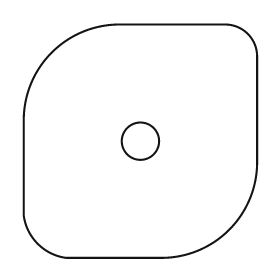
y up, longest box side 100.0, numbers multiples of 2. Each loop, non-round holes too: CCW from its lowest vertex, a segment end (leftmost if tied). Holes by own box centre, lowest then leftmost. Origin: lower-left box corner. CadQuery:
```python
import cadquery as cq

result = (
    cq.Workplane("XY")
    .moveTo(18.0, 0.0)
    .lineTo(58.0, 0.0)
    .threePointArc((88.0, 12.0), (100.0, 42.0))
    .lineTo(100.0, 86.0)
    .threePointArc((96.0, 96.0), (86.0, 100.0))
    .lineTo(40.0, 100.0)
    .threePointArc((12.0, 88.0), (0.0, 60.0))
    .lineTo(0.0, 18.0)
    .threePointArc((6.0, 6.0), (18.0, 0.0))
    .close()
    .moveTo(50.0, 50.0)
    .circle(8.0)
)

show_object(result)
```